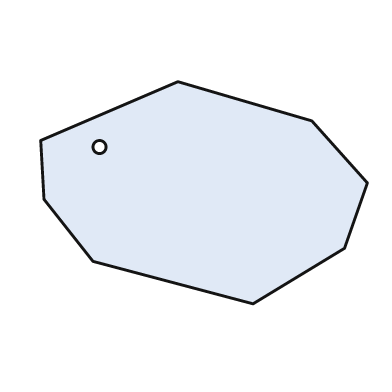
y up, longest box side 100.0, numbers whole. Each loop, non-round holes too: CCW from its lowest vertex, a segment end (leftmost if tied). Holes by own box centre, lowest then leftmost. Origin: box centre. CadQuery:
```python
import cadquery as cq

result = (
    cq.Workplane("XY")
    .moveTo(15.0, -34.0)
    .lineTo(43.0, -17.0)
    .lineTo(50.0, 3.0)
    .lineTo(33.0, 22.0)
    .lineTo(-8.0, 34.0)
    .lineTo(-50.0, 16.0)
    .lineTo(-49.0, -2.0)
    .lineTo(-34.0, -21.0)
    .close()
    .moveTo(-32.0, 14.0)
    .circle(2.0)
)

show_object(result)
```